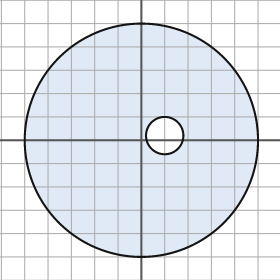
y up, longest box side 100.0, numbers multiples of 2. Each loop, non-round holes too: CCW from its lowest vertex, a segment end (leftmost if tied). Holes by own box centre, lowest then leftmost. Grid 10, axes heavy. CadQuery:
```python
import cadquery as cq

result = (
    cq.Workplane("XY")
    .moveTo(0.0, 0.0)
    .circle(50.0)
    .moveTo(10.0, 2.0)
    .circle(8.0)
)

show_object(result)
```